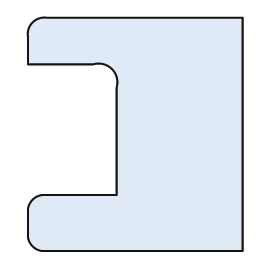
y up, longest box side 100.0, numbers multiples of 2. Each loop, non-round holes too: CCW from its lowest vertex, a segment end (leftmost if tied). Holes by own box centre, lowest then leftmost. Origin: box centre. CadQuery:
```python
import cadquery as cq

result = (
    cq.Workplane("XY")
    .moveTo(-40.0, -50.0)
    .lineTo(46.0, -50.0)
    .lineTo(46.0, 50.0)
    .lineTo(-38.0, 50.0)
    .threePointArc((-44.0, 48.0), (-46.0, 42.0))
    .lineTo(-46.0, 30.0)
    .lineTo(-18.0, 30.0)
    .threePointArc((-10.0, 28.0), (-8.0, 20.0))
    .lineTo(-8.0, -26.0)
    .lineTo(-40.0, -26.0)
    .threePointArc((-44.0, -28.0), (-46.0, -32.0))
    .lineTo(-46.0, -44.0)
    .threePointArc((-44.0, -48.0), (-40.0, -50.0))
    .close()
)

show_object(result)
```